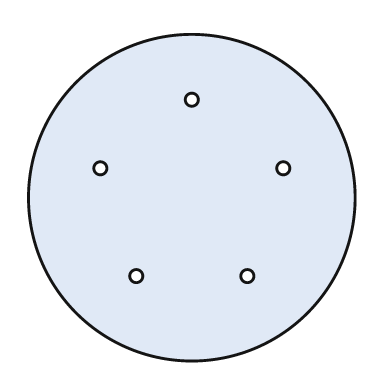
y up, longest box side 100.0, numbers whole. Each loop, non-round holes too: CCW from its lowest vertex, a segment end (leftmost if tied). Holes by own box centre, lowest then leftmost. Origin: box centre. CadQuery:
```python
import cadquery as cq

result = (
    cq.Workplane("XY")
    .moveTo(0.0, 0.0)
    .circle(50.0)
    .moveTo(-17.0, -24.0)
    .circle(2.0)
    .moveTo(17.0, -24.0)
    .circle(2.0)
    .moveTo(-28.0, 9.0)
    .circle(2.0)
    .moveTo(28.0, 9.0)
    .circle(2.0)
    .moveTo(0.0, 30.0)
    .circle(2.0)
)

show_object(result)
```